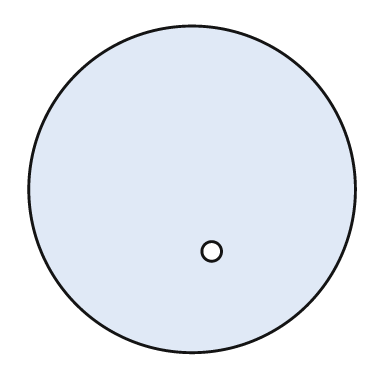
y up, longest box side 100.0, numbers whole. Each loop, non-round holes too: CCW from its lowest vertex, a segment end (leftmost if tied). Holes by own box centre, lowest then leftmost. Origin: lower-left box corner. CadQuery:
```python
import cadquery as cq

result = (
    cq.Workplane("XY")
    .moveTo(50.0, 50.0)
    .circle(50.0)
    .moveTo(56.0, 31.0)
    .circle(3.0)
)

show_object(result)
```